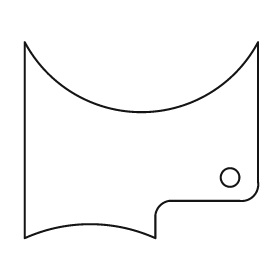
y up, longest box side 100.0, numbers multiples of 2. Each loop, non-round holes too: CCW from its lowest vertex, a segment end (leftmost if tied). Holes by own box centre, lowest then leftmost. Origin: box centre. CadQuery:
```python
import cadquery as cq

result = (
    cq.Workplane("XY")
    .moveTo(-50.0, -42.0)
    .threePointArc((-22.0, -36.0), (6.0, -42.0))
    .lineTo(6.0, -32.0)
    .threePointArc((8.0, -28.0), (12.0, -26.0))
    .lineTo(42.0, -26.0)
    .threePointArc((48.0, -24.0), (50.0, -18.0))
    .lineTo(50.0, 42.0)
    .threePointArc((0.0, 12.0), (-50.0, 42.0))
    .close()
    .moveTo(38.0, -16.0)
    .circle(4.0)
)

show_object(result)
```